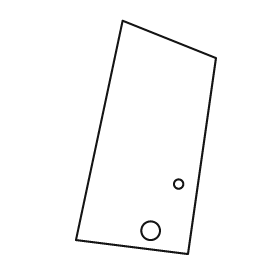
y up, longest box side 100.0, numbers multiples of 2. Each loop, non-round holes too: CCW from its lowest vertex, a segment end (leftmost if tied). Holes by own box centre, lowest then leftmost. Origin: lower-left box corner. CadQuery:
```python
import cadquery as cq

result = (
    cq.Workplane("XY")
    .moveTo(48.0, 0.0)
    .lineTo(60.0, 84.0)
    .lineTo(20.0, 100.0)
    .lineTo(0.0, 6.0)
    .close()
    .moveTo(32.0, 10.0)
    .circle(4.0)
    .moveTo(44.0, 30.0)
    .circle(2.0)
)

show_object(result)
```